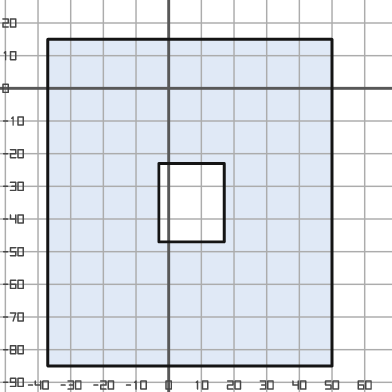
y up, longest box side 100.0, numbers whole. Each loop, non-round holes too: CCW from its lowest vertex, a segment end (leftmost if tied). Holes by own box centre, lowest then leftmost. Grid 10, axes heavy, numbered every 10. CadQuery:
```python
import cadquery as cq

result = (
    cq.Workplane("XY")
    .moveTo(-37.0, -85.0)
    .lineTo(50.0, -85.0)
    .lineTo(50.0, 15.0)
    .lineTo(-37.0, 15.0)
    .close()
    .moveTo(-3.0, -47.0)
    .lineTo(17.0, -47.0)
    .lineTo(17.0, -23.0)
    .lineTo(-3.0, -23.0)
    .close()
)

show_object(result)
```